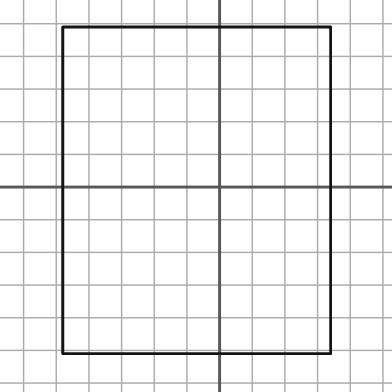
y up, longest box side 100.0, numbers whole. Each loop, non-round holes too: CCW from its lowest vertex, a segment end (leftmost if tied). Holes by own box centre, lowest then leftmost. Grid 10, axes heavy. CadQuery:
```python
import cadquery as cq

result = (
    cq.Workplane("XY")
    .moveTo(-48.0, -51.0)
    .lineTo(34.0, -51.0)
    .lineTo(34.0, 49.0)
    .lineTo(-48.0, 49.0)
    .close()
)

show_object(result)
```